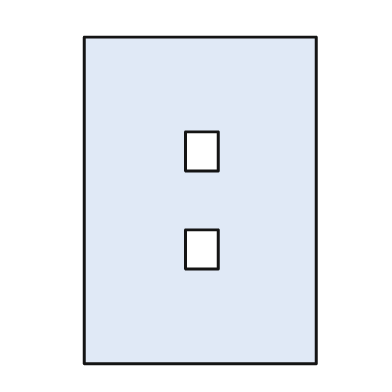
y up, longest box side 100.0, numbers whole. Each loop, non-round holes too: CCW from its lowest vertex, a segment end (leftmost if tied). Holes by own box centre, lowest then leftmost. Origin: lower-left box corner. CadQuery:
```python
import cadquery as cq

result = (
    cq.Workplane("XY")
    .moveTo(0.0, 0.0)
    .lineTo(71.0, 0.0)
    .lineTo(71.0, 100.0)
    .lineTo(0.0, 100.0)
    .close()
    .moveTo(31.0, 29.0)
    .lineTo(41.0, 29.0)
    .lineTo(41.0, 41.0)
    .lineTo(31.0, 41.0)
    .close()
    .moveTo(31.0, 59.0)
    .lineTo(41.0, 59.0)
    .lineTo(41.0, 71.0)
    .lineTo(31.0, 71.0)
    .close()
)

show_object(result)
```